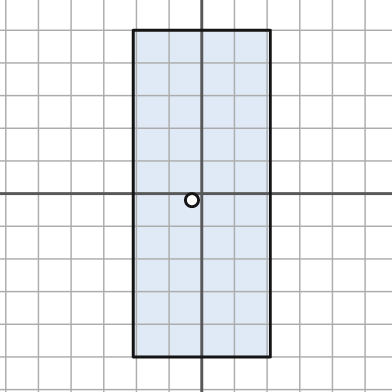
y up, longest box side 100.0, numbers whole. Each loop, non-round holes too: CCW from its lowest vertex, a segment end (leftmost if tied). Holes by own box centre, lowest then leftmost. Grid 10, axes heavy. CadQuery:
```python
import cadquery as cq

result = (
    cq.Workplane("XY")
    .moveTo(-21.0, -50.0)
    .lineTo(21.0, -50.0)
    .lineTo(21.0, 50.0)
    .lineTo(-21.0, 50.0)
    .close()
    .moveTo(-3.0, -2.0)
    .circle(2.0)
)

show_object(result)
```